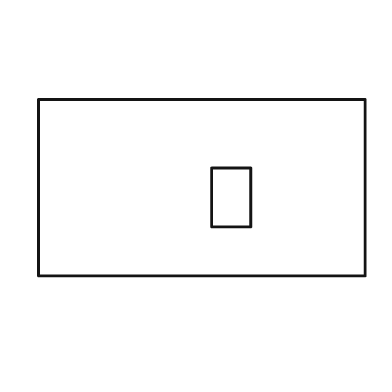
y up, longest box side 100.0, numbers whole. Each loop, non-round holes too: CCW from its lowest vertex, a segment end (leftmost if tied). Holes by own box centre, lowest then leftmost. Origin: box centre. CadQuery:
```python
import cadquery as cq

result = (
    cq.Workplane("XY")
    .moveTo(-50.0, -27.0)
    .lineTo(50.0, -27.0)
    .lineTo(50.0, 27.0)
    .lineTo(-50.0, 27.0)
    .close()
    .moveTo(3.0, -12.0)
    .lineTo(15.0, -12.0)
    .lineTo(15.0, 6.0)
    .lineTo(3.0, 6.0)
    .close()
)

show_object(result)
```